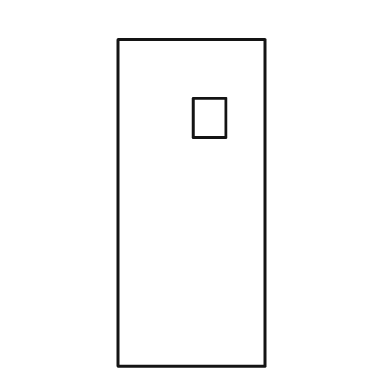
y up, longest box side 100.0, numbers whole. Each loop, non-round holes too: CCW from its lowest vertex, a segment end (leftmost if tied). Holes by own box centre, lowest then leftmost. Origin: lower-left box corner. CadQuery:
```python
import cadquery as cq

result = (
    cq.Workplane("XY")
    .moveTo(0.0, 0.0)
    .lineTo(45.0, 0.0)
    .lineTo(45.0, 100.0)
    .lineTo(0.0, 100.0)
    .close()
    .moveTo(23.0, 70.0)
    .lineTo(33.0, 70.0)
    .lineTo(33.0, 82.0)
    .lineTo(23.0, 82.0)
    .close()
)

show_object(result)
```